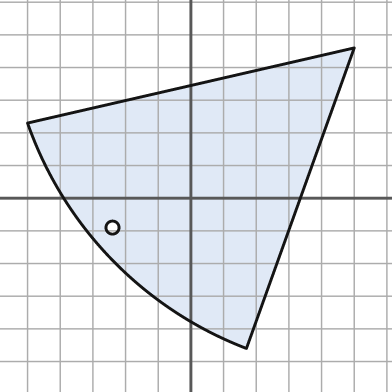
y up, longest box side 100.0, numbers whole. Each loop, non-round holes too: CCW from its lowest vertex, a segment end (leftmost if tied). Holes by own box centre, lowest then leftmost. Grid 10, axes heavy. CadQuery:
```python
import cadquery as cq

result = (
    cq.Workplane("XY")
    .moveTo(17.0, -46.0)
    .lineTo(50.0, 46.0)
    .lineTo(-50.0, 23.0)
    .threePointArc((-24.0, -19.0), (17.0, -46.0))
    .close()
    .moveTo(-24.0, -9.0)
    .circle(2.0)
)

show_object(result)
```